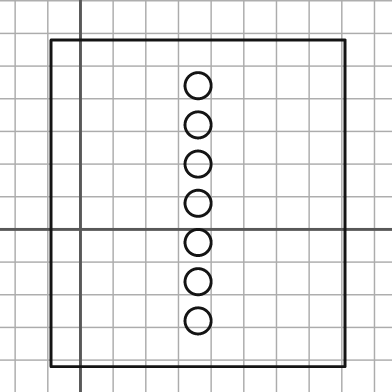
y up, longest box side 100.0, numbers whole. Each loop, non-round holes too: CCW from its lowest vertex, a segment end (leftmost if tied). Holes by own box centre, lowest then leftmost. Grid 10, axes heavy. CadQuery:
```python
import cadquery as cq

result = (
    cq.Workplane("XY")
    .moveTo(-9.0, -42.0)
    .lineTo(81.0, -42.0)
    .lineTo(81.0, 58.0)
    .lineTo(-9.0, 58.0)
    .close()
    .moveTo(36.0, -28.0)
    .circle(4.0)
    .moveTo(36.0, -16.0)
    .circle(4.0)
    .moveTo(36.0, -4.0)
    .circle(4.0)
    .moveTo(36.0, 8.0)
    .circle(4.0)
    .moveTo(36.0, 20.0)
    .circle(4.0)
    .moveTo(36.0, 32.0)
    .circle(4.0)
    .moveTo(36.0, 44.0)
    .circle(4.0)
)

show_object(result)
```